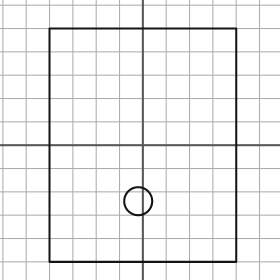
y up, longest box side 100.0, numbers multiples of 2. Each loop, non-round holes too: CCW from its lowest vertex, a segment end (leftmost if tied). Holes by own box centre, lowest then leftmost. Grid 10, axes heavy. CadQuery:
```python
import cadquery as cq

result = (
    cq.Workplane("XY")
    .moveTo(-40.0, -50.0)
    .lineTo(40.0, -50.0)
    .lineTo(40.0, 50.0)
    .lineTo(-40.0, 50.0)
    .close()
    .moveTo(-2.0, -24.0)
    .circle(6.0)
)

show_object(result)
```